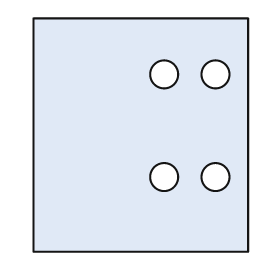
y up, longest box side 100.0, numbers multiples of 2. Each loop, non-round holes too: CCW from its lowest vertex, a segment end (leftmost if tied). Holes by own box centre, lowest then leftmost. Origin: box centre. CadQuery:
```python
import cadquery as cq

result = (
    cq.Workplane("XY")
    .moveTo(-46.0, -50.0)
    .lineTo(46.0, -50.0)
    .lineTo(46.0, 50.0)
    .lineTo(-46.0, 50.0)
    .close()
    .moveTo(10.0, -18.0)
    .circle(6.0)
    .moveTo(32.0, -18.0)
    .circle(6.0)
    .moveTo(10.0, 26.0)
    .circle(6.0)
    .moveTo(32.0, 26.0)
    .circle(6.0)
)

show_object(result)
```